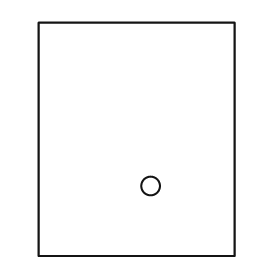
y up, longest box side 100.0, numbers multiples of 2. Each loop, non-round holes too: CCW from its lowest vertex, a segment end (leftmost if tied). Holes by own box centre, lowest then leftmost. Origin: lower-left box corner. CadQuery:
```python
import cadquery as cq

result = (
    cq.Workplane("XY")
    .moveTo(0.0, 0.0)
    .lineTo(84.0, 0.0)
    .lineTo(84.0, 100.0)
    .lineTo(0.0, 100.0)
    .close()
    .moveTo(48.0, 30.0)
    .circle(4.0)
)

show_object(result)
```